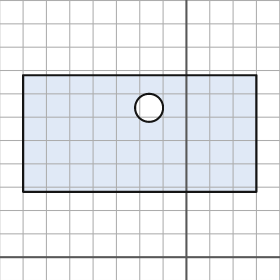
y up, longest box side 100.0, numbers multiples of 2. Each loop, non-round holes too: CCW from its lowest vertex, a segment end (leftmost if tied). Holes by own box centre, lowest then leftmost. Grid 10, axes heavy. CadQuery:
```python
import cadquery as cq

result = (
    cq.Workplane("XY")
    .moveTo(-70.0, 28.0)
    .lineTo(30.0, 28.0)
    .lineTo(30.0, 78.0)
    .lineTo(-70.0, 78.0)
    .close()
    .moveTo(-16.0, 64.0)
    .circle(6.0)
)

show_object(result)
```